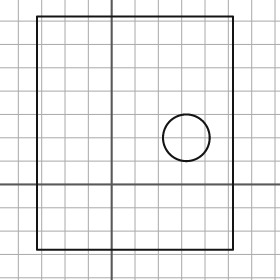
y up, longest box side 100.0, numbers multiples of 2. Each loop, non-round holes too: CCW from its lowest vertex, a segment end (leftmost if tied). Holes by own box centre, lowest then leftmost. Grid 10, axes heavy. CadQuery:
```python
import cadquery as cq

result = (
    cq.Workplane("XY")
    .moveTo(-32.0, -28.0)
    .lineTo(52.0, -28.0)
    .lineTo(52.0, 72.0)
    .lineTo(-32.0, 72.0)
    .close()
    .moveTo(32.0, 20.0)
    .circle(10.0)
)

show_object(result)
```